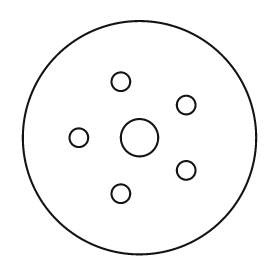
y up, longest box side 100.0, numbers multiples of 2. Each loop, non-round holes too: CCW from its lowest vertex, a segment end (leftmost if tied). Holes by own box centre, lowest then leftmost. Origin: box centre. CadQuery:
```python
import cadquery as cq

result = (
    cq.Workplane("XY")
    .moveTo(0.0, 0.0)
    .circle(50.0)
    .moveTo(-8.0, -24.0)
    .circle(4.0)
    .moveTo(20.0, -14.0)
    .circle(4.0)
    .moveTo(-26.0, 0.0)
    .circle(4.0)
    .moveTo(0.0, 0.0)
    .circle(8.0)
    .moveTo(20.0, 14.0)
    .circle(4.0)
    .moveTo(-8.0, 24.0)
    .circle(4.0)
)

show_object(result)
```